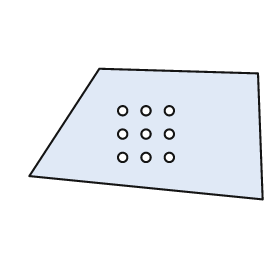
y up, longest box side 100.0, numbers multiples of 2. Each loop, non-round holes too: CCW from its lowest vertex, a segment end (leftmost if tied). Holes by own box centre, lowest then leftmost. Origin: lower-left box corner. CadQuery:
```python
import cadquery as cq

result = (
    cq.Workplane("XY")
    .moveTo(100.0, 0.0)
    .lineTo(98.0, 54.0)
    .lineTo(30.0, 56.0)
    .lineTo(0.0, 10.0)
    .close()
    .moveTo(40.0, 18.0)
    .circle(2.0)
    .moveTo(50.0, 18.0)
    .circle(2.0)
    .moveTo(60.0, 18.0)
    .circle(2.0)
    .moveTo(40.0, 28.0)
    .circle(2.0)
    .moveTo(50.0, 28.0)
    .circle(2.0)
    .moveTo(60.0, 28.0)
    .circle(2.0)
    .moveTo(40.0, 38.0)
    .circle(2.0)
    .moveTo(50.0, 38.0)
    .circle(2.0)
    .moveTo(60.0, 38.0)
    .circle(2.0)
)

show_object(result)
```